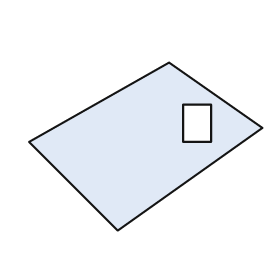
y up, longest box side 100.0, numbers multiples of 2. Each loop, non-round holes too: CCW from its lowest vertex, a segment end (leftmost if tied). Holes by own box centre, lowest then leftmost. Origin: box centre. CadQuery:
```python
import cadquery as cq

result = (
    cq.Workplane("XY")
    .moveTo(-12.0, -36.0)
    .lineTo(50.0, 8.0)
    .lineTo(10.0, 36.0)
    .lineTo(-50.0, 2.0)
    .close()
    .moveTo(16.0, 2.0)
    .lineTo(28.0, 2.0)
    .lineTo(28.0, 18.0)
    .lineTo(16.0, 18.0)
    .close()
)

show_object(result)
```